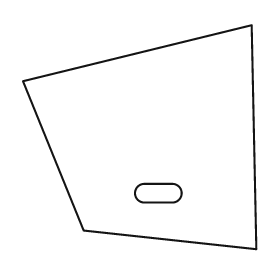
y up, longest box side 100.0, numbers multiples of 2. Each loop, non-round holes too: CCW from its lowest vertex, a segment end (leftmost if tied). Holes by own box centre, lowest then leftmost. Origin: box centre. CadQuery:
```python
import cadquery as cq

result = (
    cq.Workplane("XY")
    .moveTo(50.0, -48.0)
    .lineTo(48.0, 48.0)
    .lineTo(-50.0, 24.0)
    .lineTo(-24.0, -40.0)
    .close()
    .moveTo(2.0, -28.0)
    .lineTo(14.0, -28.0)
    .threePointArc((18.0, -24.0), (14.0, -20.0))
    .lineTo(2.0, -20.0)
    .threePointArc((-2.0, -24.0), (2.0, -28.0))
    .close()
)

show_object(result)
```